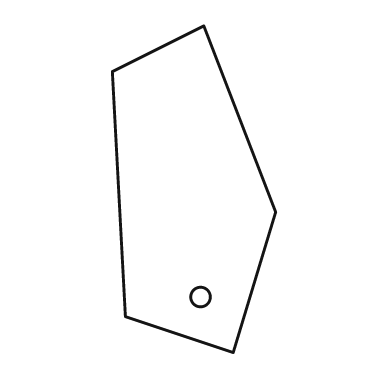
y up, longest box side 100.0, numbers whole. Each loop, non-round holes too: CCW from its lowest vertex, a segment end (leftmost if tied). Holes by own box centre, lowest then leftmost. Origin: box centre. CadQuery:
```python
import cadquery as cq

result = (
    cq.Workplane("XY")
    .moveTo(12.0, -50.0)
    .lineTo(25.0, -7.0)
    .lineTo(3.0, 50.0)
    .lineTo(-25.0, 36.0)
    .lineTo(-21.0, -39.0)
    .close()
    .moveTo(2.0, -33.0)
    .circle(3.0)
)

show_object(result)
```